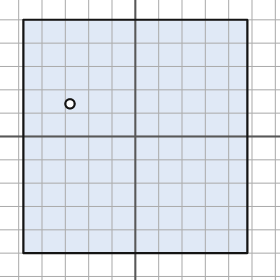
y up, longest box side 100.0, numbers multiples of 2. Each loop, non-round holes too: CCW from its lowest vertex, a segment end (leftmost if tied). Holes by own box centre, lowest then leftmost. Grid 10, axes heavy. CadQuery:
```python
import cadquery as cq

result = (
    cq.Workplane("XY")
    .moveTo(-48.0, -50.0)
    .lineTo(48.0, -50.0)
    .lineTo(48.0, 50.0)
    .lineTo(-48.0, 50.0)
    .close()
    .moveTo(-28.0, 14.0)
    .circle(2.0)
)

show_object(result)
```